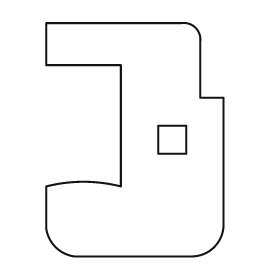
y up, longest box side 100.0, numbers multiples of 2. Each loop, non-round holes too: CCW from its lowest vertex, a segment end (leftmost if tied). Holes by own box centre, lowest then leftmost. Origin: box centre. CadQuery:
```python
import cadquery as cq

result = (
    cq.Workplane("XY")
    .moveTo(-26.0, -50.0)
    .lineTo(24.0, -50.0)
    .threePointArc((34.0, -46.0), (38.0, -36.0))
    .lineTo(38.0, 18.0)
    .lineTo(28.0, 18.0)
    .lineTo(28.0, 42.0)
    .threePointArc((26.0, 48.0), (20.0, 50.0))
    .lineTo(-38.0, 50.0)
    .lineTo(-38.0, 32.0)
    .lineTo(-6.0, 32.0)
    .lineTo(-6.0, -20.0)
    .threePointArc((-22.0, -18.0), (-38.0, -20.0))
    .lineTo(-38.0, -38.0)
    .threePointArc((-34.0, -46.0), (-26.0, -50.0))
    .close()
    .moveTo(10.0, -6.0)
    .lineTo(22.0, -6.0)
    .lineTo(22.0, 6.0)
    .lineTo(10.0, 6.0)
    .close()
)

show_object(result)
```